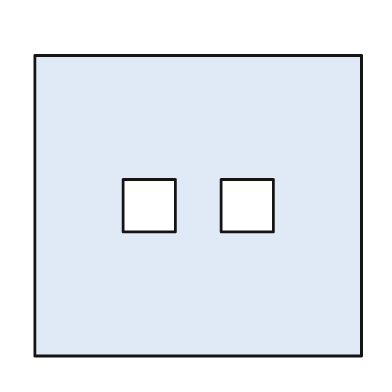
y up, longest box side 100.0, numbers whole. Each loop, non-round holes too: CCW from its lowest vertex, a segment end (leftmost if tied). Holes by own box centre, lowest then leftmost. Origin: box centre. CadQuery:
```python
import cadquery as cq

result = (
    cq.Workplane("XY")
    .moveTo(-50.0, -46.0)
    .lineTo(50.0, -46.0)
    .lineTo(50.0, 46.0)
    .lineTo(-50.0, 46.0)
    .close()
    .moveTo(-23.0, -8.0)
    .lineTo(-7.0, -8.0)
    .lineTo(-7.0, 8.0)
    .lineTo(-23.0, 8.0)
    .close()
    .moveTo(7.0, -8.0)
    .lineTo(23.0, -8.0)
    .lineTo(23.0, 8.0)
    .lineTo(7.0, 8.0)
    .close()
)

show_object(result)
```